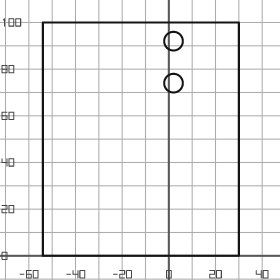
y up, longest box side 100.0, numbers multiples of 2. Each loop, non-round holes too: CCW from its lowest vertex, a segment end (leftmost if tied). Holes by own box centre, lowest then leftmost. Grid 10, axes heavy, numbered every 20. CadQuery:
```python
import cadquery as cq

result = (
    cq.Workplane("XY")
    .moveTo(-54.0, 0.0)
    .lineTo(30.0, 0.0)
    .lineTo(30.0, 100.0)
    .lineTo(-54.0, 100.0)
    .close()
    .moveTo(2.0, 74.0)
    .circle(4.0)
    .moveTo(2.0, 92.0)
    .circle(4.0)
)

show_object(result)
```